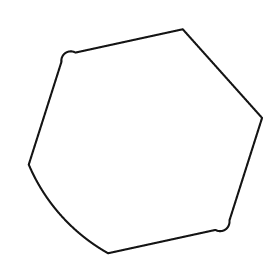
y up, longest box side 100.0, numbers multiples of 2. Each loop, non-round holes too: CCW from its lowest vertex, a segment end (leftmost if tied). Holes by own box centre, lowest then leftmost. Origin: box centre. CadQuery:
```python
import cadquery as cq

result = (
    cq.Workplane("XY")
    .moveTo(-16.0, -48.0)
    .lineTo(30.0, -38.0)
    .threePointArc((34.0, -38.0), (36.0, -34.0))
    .lineTo(50.0, 10.0)
    .lineTo(16.0, 48.0)
    .lineTo(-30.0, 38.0)
    .threePointArc((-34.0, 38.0), (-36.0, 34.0))
    .lineTo(-50.0, -10.0)
    .threePointArc((-36.0, -32.0), (-16.0, -48.0))
    .close()
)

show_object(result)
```